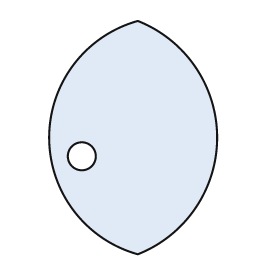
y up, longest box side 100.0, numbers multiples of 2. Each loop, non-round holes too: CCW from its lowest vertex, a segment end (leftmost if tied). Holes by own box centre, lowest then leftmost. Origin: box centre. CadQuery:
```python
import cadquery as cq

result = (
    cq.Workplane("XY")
    .moveTo(2.0, -50.0)
    .threePointArc((36.0, 0.0), (2.0, 50.0))
    .threePointArc((-36.0, 0.0), (2.0, -50.0))
    .close()
    .moveTo(-22.0, -8.0)
    .circle(6.0)
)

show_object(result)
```